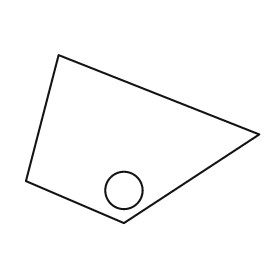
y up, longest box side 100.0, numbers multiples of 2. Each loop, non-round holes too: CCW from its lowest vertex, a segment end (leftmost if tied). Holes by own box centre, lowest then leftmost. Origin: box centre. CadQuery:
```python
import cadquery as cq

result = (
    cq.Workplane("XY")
    .moveTo(-8.0, -36.0)
    .lineTo(50.0, 2.0)
    .lineTo(-36.0, 36.0)
    .lineTo(-50.0, -18.0)
    .close()
    .moveTo(-8.0, -22.0)
    .circle(8.0)
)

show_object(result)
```